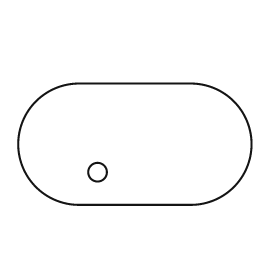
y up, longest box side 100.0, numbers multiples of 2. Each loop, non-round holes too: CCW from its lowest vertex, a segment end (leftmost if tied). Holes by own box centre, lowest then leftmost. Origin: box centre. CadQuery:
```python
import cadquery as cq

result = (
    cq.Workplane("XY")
    .moveTo(-24.0, -26.0)
    .lineTo(24.0, -26.0)
    .threePointArc((50.0, 0.0), (24.0, 26.0))
    .lineTo(-24.0, 26.0)
    .threePointArc((-50.0, 0.0), (-24.0, -26.0))
    .close()
    .moveTo(-16.0, -12.0)
    .circle(4.0)
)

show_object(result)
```